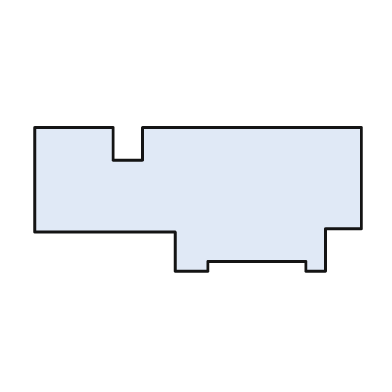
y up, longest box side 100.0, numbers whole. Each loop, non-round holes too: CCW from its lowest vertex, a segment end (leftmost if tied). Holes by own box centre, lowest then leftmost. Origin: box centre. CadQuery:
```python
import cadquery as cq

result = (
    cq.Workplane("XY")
    .moveTo(-7.0, -22.0)
    .lineTo(3.0, -22.0)
    .lineTo(3.0, -19.0)
    .lineTo(33.0, -19.0)
    .lineTo(33.0, -22.0)
    .lineTo(39.0, -22.0)
    .lineTo(39.0, -9.0)
    .lineTo(50.0, -9.0)
    .lineTo(50.0, 22.0)
    .lineTo(-17.0, 22.0)
    .lineTo(-17.0, 12.0)
    .lineTo(-26.0, 12.0)
    .lineTo(-26.0, 22.0)
    .lineTo(-50.0, 22.0)
    .lineTo(-50.0, -10.0)
    .lineTo(-7.0, -10.0)
    .close()
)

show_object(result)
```